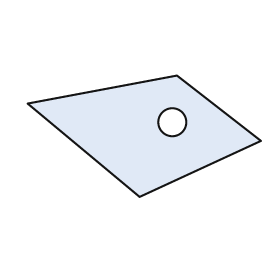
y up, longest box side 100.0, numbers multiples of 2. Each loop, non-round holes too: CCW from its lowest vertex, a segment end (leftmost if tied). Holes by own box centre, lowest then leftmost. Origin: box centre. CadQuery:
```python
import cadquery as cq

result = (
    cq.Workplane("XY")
    .moveTo(-2.0, -26.0)
    .lineTo(50.0, -2.0)
    .lineTo(14.0, 26.0)
    .lineTo(-50.0, 14.0)
    .close()
    .moveTo(12.0, 6.0)
    .circle(6.0)
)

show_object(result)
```